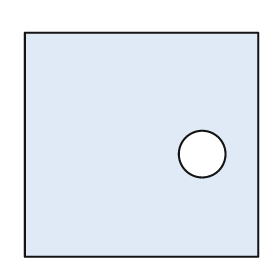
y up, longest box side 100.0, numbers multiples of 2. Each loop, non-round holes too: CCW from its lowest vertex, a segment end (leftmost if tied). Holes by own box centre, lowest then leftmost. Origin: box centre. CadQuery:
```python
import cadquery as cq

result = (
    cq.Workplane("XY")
    .moveTo(-50.0, -48.0)
    .lineTo(50.0, -48.0)
    .lineTo(50.0, 48.0)
    .lineTo(-50.0, 48.0)
    .close()
    .moveTo(26.0, -4.0)
    .circle(10.0)
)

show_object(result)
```